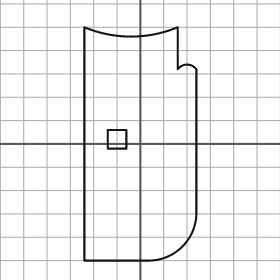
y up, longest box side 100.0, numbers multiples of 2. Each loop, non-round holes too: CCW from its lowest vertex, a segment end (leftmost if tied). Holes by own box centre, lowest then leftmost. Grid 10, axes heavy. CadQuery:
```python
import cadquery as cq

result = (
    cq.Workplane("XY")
    .moveTo(-24.0, -50.0)
    .lineTo(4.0, -50.0)
    .threePointArc((18.0, -44.0), (24.0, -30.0))
    .lineTo(24.0, 32.0)
    .threePointArc((20.0, 34.0), (16.0, 32.0))
    .lineTo(16.0, 50.0)
    .threePointArc((-4.0, 46.0), (-24.0, 50.0))
    .close()
    .moveTo(-14.0, -2.0)
    .lineTo(-6.0, -2.0)
    .lineTo(-6.0, 6.0)
    .lineTo(-14.0, 6.0)
    .close()
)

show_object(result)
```